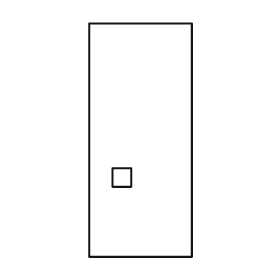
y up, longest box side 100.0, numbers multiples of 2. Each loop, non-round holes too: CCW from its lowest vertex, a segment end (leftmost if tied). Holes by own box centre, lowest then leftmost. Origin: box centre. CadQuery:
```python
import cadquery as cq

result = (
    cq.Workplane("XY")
    .moveTo(-22.0, -50.0)
    .lineTo(22.0, -50.0)
    .lineTo(22.0, 50.0)
    .lineTo(-22.0, 50.0)
    .close()
    .moveTo(-12.0, -20.0)
    .lineTo(-4.0, -20.0)
    .lineTo(-4.0, -12.0)
    .lineTo(-12.0, -12.0)
    .close()
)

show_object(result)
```